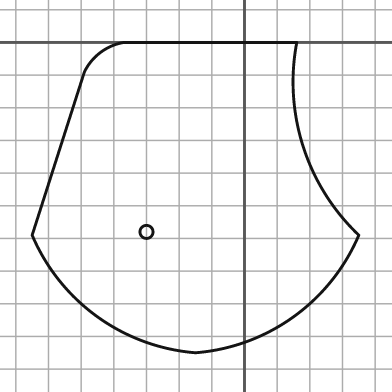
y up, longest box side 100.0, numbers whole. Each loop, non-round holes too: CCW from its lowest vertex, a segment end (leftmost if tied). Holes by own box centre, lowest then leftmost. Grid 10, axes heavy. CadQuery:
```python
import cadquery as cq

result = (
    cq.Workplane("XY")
    .moveTo(-15.0, -95.0)
    .threePointArc((15.0, -84.0), (35.0, -59.0))
    .threePointArc((18.0, -32.0), (16.0, 0.0))
    .lineTo(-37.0, 0.0)
    .threePointArc((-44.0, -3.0), (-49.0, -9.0))
    .lineTo(-65.0, -59.0)
    .threePointArc((-45.0, -84.0), (-15.0, -95.0))
    .close()
    .moveTo(-30.0, -58.0)
    .circle(2.0)
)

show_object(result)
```